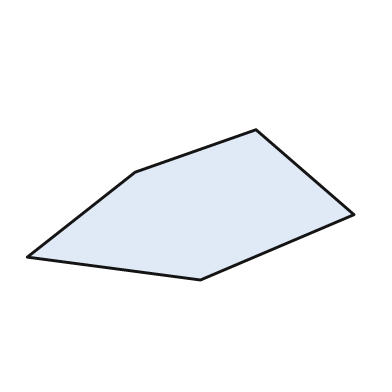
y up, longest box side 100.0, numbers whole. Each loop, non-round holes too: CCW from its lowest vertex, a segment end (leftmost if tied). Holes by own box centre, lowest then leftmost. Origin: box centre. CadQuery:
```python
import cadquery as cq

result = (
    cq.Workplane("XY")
    .moveTo(3.0, -23.0)
    .lineTo(50.0, -3.0)
    .lineTo(20.0, 23.0)
    .lineTo(-17.0, 10.0)
    .lineTo(-50.0, -16.0)
    .close()
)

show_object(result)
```